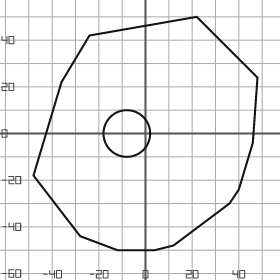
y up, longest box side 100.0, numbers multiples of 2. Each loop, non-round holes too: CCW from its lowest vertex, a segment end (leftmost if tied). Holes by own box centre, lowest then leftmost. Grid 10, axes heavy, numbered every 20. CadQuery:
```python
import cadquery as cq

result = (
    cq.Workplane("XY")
    .moveTo(-12.0, -50.0)
    .lineTo(4.0, -50.0)
    .lineTo(12.0, -48.0)
    .lineTo(36.0, -30.0)
    .lineTo(40.0, -24.0)
    .lineTo(46.0, -4.0)
    .lineTo(48.0, 24.0)
    .lineTo(22.0, 50.0)
    .lineTo(-24.0, 42.0)
    .lineTo(-36.0, 22.0)
    .lineTo(-48.0, -18.0)
    .lineTo(-28.0, -44.0)
    .close()
    .moveTo(-8.0, 0.0)
    .circle(10.0)
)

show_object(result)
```